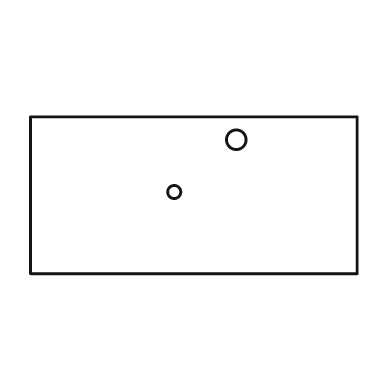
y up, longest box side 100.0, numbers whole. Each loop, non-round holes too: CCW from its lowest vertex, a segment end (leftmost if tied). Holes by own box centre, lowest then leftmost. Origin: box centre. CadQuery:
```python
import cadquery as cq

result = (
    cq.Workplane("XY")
    .moveTo(-50.0, -24.0)
    .lineTo(50.0, -24.0)
    .lineTo(50.0, 24.0)
    .lineTo(-50.0, 24.0)
    .close()
    .moveTo(-6.0, 1.0)
    .circle(2.0)
    .moveTo(13.0, 17.0)
    .circle(3.0)
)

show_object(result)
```